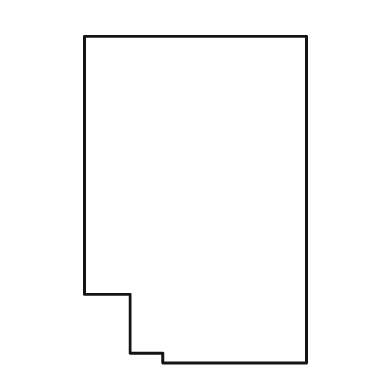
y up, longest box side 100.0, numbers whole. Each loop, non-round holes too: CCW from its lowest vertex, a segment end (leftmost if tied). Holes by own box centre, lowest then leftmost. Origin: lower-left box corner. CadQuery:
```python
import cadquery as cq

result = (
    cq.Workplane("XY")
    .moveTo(24.0, 0.0)
    .lineTo(68.0, 0.0)
    .lineTo(68.0, 100.0)
    .lineTo(0.0, 100.0)
    .lineTo(0.0, 21.0)
    .lineTo(14.0, 21.0)
    .lineTo(14.0, 3.0)
    .lineTo(24.0, 3.0)
    .close()
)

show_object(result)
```